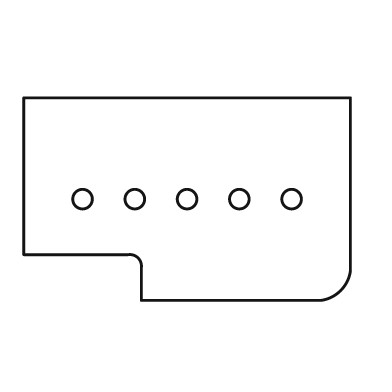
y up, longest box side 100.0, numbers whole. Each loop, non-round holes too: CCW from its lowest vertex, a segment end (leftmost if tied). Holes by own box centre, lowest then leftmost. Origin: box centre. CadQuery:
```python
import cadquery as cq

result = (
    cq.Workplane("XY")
    .moveTo(-14.0, -31.0)
    .lineTo(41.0, -31.0)
    .threePointArc((47.0, -28.0), (50.0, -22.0))
    .lineTo(50.0, 31.0)
    .lineTo(-50.0, 31.0)
    .lineTo(-50.0, -17.0)
    .lineTo(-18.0, -17.0)
    .threePointArc((-15.0, -18.0), (-14.0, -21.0))
    .close()
    .moveTo(-32.0, 0.0)
    .circle(3.0)
    .moveTo(-16.0, 0.0)
    .circle(3.0)
    .moveTo(0.0, 0.0)
    .circle(3.0)
    .moveTo(16.0, 0.0)
    .circle(3.0)
    .moveTo(32.0, 0.0)
    .circle(3.0)
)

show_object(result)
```